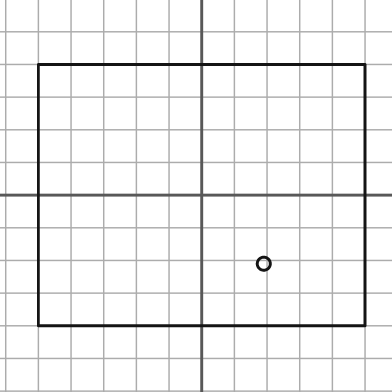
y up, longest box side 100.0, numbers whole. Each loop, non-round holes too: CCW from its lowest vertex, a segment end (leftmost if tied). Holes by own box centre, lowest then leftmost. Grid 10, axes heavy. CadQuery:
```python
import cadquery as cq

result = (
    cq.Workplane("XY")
    .moveTo(-50.0, -40.0)
    .lineTo(50.0, -40.0)
    .lineTo(50.0, 40.0)
    .lineTo(-50.0, 40.0)
    .close()
    .moveTo(19.0, -21.0)
    .circle(2.0)
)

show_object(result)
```